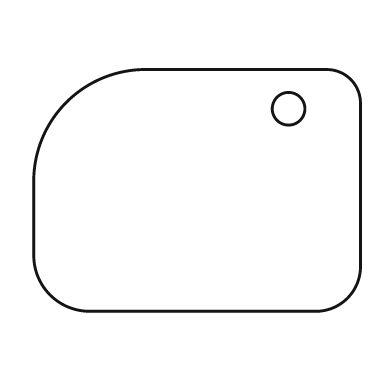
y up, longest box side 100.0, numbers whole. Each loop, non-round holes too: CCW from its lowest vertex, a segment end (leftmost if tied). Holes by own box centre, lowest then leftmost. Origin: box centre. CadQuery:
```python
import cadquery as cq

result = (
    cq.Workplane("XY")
    .moveTo(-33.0, -37.0)
    .lineTo(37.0, -37.0)
    .threePointArc((46.0, -33.0), (50.0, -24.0))
    .lineTo(50.0, 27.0)
    .threePointArc((47.0, 34.0), (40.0, 37.0))
    .lineTo(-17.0, 37.0)
    .threePointArc((-40.0, 27.0), (-50.0, 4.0))
    .lineTo(-50.0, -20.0)
    .threePointArc((-45.0, -32.0), (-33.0, -37.0))
    .close()
    .moveTo(28.0, 25.0)
    .circle(5.0)
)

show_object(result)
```